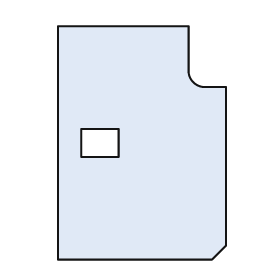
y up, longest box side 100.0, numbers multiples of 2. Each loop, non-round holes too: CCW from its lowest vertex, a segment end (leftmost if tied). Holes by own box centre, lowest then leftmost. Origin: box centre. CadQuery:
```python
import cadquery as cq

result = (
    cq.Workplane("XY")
    .moveTo(-36.0, -50.0)
    .lineTo(30.0, -50.0)
    .lineTo(36.0, -44.0)
    .lineTo(36.0, 24.0)
    .lineTo(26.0, 24.0)
    .threePointArc((22.0, 26.0), (20.0, 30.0))
    .lineTo(20.0, 50.0)
    .lineTo(-36.0, 50.0)
    .close()
    .moveTo(-26.0, -6.0)
    .lineTo(-10.0, -6.0)
    .lineTo(-10.0, 6.0)
    .lineTo(-26.0, 6.0)
    .close()
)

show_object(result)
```